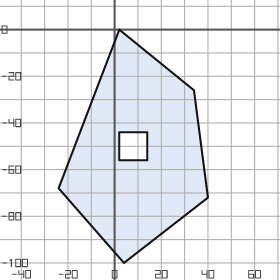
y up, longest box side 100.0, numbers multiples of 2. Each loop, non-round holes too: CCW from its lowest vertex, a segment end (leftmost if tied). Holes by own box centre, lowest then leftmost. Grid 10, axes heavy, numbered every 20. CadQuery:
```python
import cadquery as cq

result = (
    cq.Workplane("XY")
    .moveTo(4.0, -100.0)
    .lineTo(40.0, -72.0)
    .lineTo(34.0, -26.0)
    .lineTo(2.0, 0.0)
    .lineTo(-24.0, -68.0)
    .close()
    .moveTo(2.0, -56.0)
    .lineTo(14.0, -56.0)
    .lineTo(14.0, -44.0)
    .lineTo(2.0, -44.0)
    .close()
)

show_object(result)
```